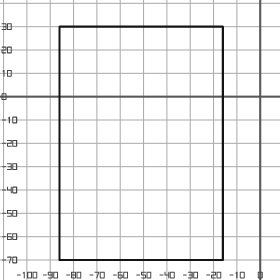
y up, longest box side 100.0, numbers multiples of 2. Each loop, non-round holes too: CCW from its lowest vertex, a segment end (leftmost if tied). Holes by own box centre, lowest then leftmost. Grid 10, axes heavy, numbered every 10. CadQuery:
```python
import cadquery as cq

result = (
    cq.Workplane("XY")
    .moveTo(-86.0, -70.0)
    .lineTo(-16.0, -70.0)
    .lineTo(-16.0, 30.0)
    .lineTo(-86.0, 30.0)
    .close()
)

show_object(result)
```